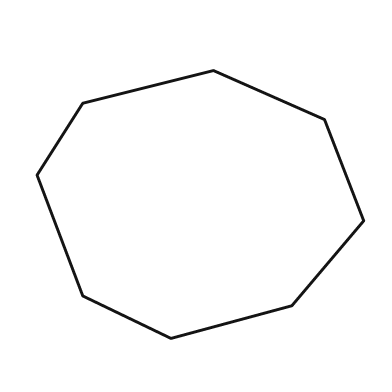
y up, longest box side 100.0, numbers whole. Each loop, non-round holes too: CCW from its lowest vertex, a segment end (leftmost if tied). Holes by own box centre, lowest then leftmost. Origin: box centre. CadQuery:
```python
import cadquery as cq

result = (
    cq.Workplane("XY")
    .moveTo(-9.0, -41.0)
    .lineTo(28.0, -31.0)
    .lineTo(50.0, -5.0)
    .lineTo(38.0, 26.0)
    .lineTo(4.0, 41.0)
    .lineTo(-36.0, 31.0)
    .lineTo(-50.0, 9.0)
    .lineTo(-36.0, -28.0)
    .close()
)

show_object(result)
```